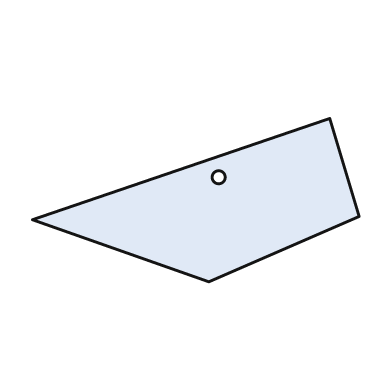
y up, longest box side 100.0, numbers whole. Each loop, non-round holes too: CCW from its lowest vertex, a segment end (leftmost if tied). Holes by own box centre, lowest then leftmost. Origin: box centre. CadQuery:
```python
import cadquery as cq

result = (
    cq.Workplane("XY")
    .moveTo(4.0, -25.0)
    .lineTo(50.0, -5.0)
    .lineTo(41.0, 25.0)
    .lineTo(-50.0, -6.0)
    .close()
    .moveTo(7.0, 7.0)
    .circle(2.0)
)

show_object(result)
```